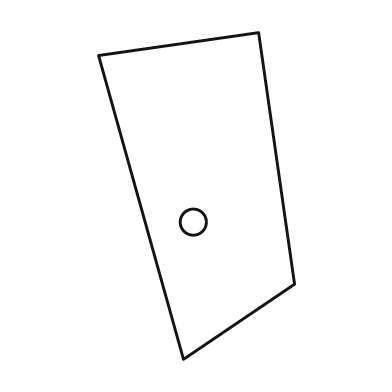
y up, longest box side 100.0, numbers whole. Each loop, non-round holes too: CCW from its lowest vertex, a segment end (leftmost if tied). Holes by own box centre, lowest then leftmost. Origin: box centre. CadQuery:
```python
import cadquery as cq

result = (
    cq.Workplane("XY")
    .moveTo(-4.0, -50.0)
    .lineTo(30.0, -27.0)
    .lineTo(19.0, 50.0)
    .lineTo(-30.0, 43.0)
    .close()
    .moveTo(-1.0, -8.0)
    .circle(4.0)
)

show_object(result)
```